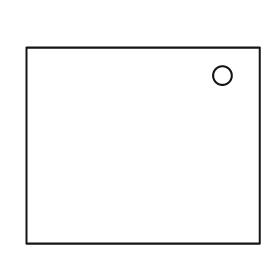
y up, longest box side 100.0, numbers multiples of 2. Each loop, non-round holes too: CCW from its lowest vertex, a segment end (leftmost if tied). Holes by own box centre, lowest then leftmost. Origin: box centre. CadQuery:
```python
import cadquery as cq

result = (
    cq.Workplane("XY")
    .moveTo(-50.0, -42.0)
    .lineTo(50.0, -42.0)
    .lineTo(50.0, 42.0)
    .lineTo(-50.0, 42.0)
    .close()
    .moveTo(34.0, 30.0)
    .circle(4.0)
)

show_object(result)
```